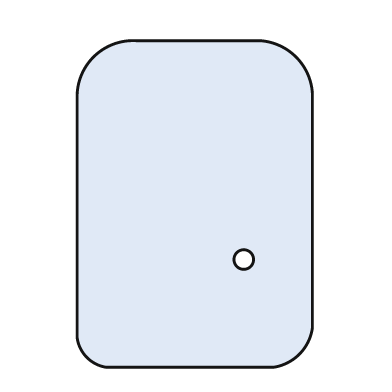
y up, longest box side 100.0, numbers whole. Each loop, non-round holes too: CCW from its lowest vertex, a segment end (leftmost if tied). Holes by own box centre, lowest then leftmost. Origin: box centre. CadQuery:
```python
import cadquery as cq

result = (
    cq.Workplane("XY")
    .moveTo(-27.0, -50.0)
    .lineTo(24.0, -50.0)
    .threePointArc((32.0, -46.0), (36.0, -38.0))
    .lineTo(36.0, 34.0)
    .threePointArc((31.0, 45.0), (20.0, 50.0))
    .lineTo(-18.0, 50.0)
    .threePointArc((-31.0, 45.0), (-36.0, 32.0))
    .lineTo(-36.0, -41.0)
    .threePointArc((-33.0, -47.0), (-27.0, -50.0))
    .close()
    .moveTo(15.0, -17.0)
    .circle(3.0)
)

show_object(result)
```